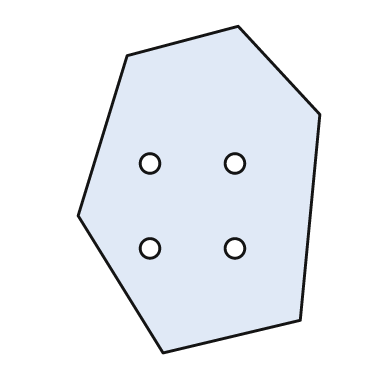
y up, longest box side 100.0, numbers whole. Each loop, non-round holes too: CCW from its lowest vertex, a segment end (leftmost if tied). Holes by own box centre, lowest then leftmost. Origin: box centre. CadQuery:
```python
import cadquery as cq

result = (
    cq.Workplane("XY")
    .moveTo(-11.0, -50.0)
    .lineTo(31.0, -40.0)
    .lineTo(37.0, 23.0)
    .lineTo(12.0, 50.0)
    .lineTo(-22.0, 41.0)
    .lineTo(-37.0, -8.0)
    .close()
    .moveTo(-15.0, -18.0)
    .circle(3.0)
    .moveTo(11.0, -18.0)
    .circle(3.0)
    .moveTo(-15.0, 8.0)
    .circle(3.0)
    .moveTo(11.0, 8.0)
    .circle(3.0)
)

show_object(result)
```